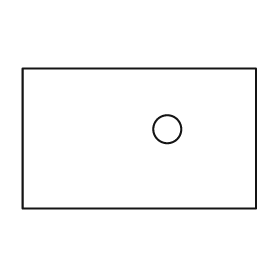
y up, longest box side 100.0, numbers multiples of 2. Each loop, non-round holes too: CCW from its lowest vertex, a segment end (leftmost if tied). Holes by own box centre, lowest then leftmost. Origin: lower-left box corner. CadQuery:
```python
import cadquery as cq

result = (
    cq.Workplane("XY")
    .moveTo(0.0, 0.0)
    .lineTo(100.0, 0.0)
    .lineTo(100.0, 60.0)
    .lineTo(0.0, 60.0)
    .close()
    .moveTo(62.0, 34.0)
    .circle(6.0)
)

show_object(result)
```